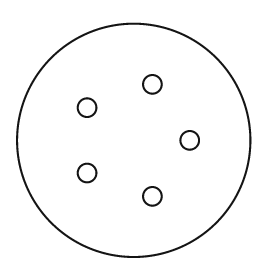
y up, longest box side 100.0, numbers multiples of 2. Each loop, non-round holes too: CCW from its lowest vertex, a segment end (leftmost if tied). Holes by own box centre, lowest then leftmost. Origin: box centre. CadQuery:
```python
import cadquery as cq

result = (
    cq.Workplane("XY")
    .moveTo(0.0, 0.0)
    .circle(50.0)
    .moveTo(8.0, -24.0)
    .circle(4.0)
    .moveTo(-20.0, -14.0)
    .circle(4.0)
    .moveTo(24.0, 0.0)
    .circle(4.0)
    .moveTo(-20.0, 14.0)
    .circle(4.0)
    .moveTo(8.0, 24.0)
    .circle(4.0)
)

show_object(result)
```